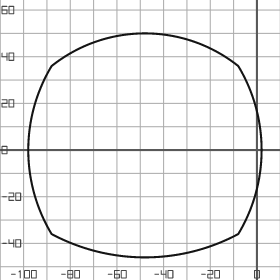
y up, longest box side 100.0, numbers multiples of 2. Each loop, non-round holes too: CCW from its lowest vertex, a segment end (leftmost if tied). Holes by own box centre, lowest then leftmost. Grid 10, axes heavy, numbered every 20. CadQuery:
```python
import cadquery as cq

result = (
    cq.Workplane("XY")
    .moveTo(-88.0, -36.0)
    .threePointArc((-48.0, -46.0), (-8.0, -36.0))
    .threePointArc((2.0, 0.0), (-8.0, 36.0))
    .threePointArc((-48.0, 50.0), (-88.0, 36.0))
    .threePointArc((-98.0, 0.0), (-88.0, -36.0))
    .close()
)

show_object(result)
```